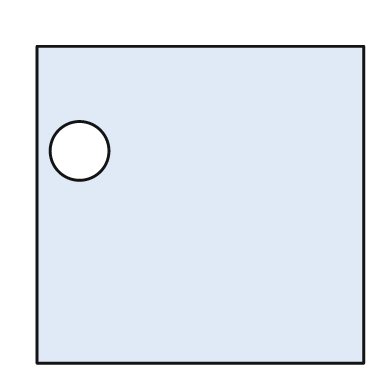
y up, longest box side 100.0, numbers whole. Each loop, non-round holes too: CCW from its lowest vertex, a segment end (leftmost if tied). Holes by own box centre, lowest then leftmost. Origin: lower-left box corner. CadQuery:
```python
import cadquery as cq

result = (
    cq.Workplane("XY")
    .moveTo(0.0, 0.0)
    .lineTo(100.0, 0.0)
    .lineTo(100.0, 97.0)
    .lineTo(0.0, 97.0)
    .close()
    .moveTo(13.0, 65.0)
    .circle(9.0)
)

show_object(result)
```